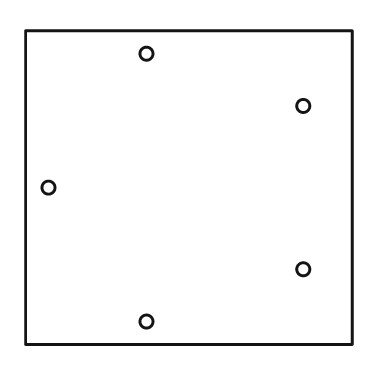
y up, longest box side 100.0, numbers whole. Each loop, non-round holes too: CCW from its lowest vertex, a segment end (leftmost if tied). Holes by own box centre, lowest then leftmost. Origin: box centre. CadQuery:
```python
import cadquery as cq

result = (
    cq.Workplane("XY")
    .moveTo(-50.0, -48.0)
    .lineTo(50.0, -48.0)
    .lineTo(50.0, 48.0)
    .lineTo(-50.0, 48.0)
    .close()
    .moveTo(-13.0, -41.0)
    .circle(2.0)
    .moveTo(35.0, -25.0)
    .circle(2.0)
    .moveTo(-43.0, 0.0)
    .circle(2.0)
    .moveTo(35.0, 25.0)
    .circle(2.0)
    .moveTo(-13.0, 41.0)
    .circle(2.0)
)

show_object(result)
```